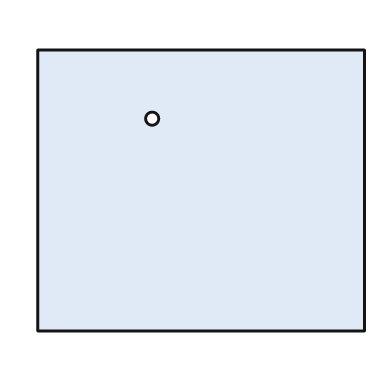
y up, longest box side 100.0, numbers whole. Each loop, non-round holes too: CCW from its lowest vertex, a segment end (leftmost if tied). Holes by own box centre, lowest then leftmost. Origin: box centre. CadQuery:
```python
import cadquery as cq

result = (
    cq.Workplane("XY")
    .moveTo(-50.0, -43.0)
    .lineTo(50.0, -43.0)
    .lineTo(50.0, 43.0)
    .lineTo(-50.0, 43.0)
    .close()
    .moveTo(-15.0, 22.0)
    .circle(2.0)
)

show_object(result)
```